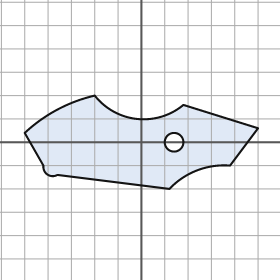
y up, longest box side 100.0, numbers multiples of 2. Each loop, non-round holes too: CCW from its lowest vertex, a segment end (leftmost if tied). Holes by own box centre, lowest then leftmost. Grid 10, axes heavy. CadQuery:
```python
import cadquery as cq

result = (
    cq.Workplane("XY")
    .moveTo(12.0, -20.0)
    .threePointArc((24.0, -12.0), (38.0, -10.0))
    .lineTo(50.0, 6.0)
    .lineTo(18.0, 16.0)
    .threePointArc((-2.0, 10.0), (-20.0, 20.0))
    .threePointArc((-36.0, 14.0), (-50.0, 4.0))
    .lineTo(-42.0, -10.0)
    .threePointArc((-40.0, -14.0), (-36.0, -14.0))
    .close()
    .moveTo(14.0, 0.0)
    .circle(4.0)
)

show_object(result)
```